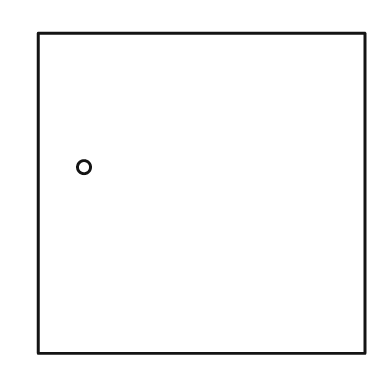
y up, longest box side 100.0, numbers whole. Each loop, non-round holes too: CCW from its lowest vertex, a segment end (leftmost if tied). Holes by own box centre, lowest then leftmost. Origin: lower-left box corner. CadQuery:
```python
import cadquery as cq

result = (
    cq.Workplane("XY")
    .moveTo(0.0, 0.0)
    .lineTo(100.0, 0.0)
    .lineTo(100.0, 98.0)
    .lineTo(0.0, 98.0)
    .close()
    .moveTo(14.0, 57.0)
    .circle(2.0)
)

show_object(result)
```